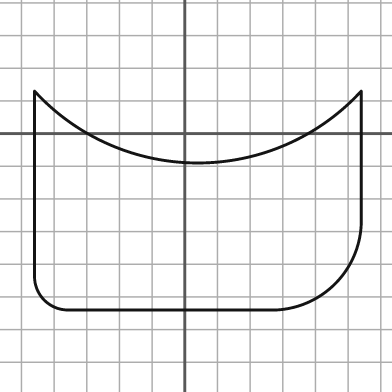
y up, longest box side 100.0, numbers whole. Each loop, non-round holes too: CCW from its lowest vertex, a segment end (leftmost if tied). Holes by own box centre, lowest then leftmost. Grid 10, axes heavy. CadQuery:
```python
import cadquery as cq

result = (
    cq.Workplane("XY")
    .moveTo(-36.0, -54.0)
    .lineTo(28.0, -54.0)
    .threePointArc((46.0, -46.0), (54.0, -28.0))
    .lineTo(54.0, 13.0)
    .threePointArc((4.0, -9.0), (-46.0, 13.0))
    .lineTo(-46.0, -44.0)
    .threePointArc((-43.0, -51.0), (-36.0, -54.0))
    .close()
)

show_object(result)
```